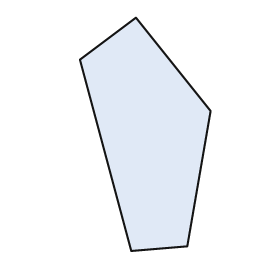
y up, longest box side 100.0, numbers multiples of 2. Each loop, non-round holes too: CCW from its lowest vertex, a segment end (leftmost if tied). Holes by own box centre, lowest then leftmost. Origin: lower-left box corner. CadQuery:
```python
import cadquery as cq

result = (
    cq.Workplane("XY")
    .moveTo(22.0, 0.0)
    .lineTo(46.0, 2.0)
    .lineTo(56.0, 60.0)
    .lineTo(24.0, 100.0)
    .lineTo(0.0, 82.0)
    .close()
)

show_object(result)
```